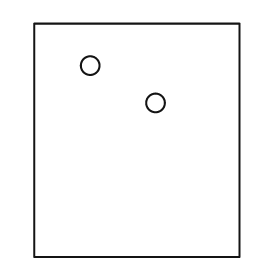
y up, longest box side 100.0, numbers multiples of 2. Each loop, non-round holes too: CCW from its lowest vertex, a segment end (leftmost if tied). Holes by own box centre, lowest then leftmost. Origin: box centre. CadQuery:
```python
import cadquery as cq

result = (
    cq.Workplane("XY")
    .moveTo(-44.0, -50.0)
    .lineTo(44.0, -50.0)
    .lineTo(44.0, 50.0)
    .lineTo(-44.0, 50.0)
    .close()
    .moveTo(8.0, 16.0)
    .circle(4.0)
    .moveTo(-20.0, 32.0)
    .circle(4.0)
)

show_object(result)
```